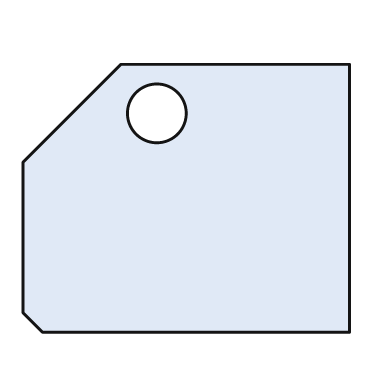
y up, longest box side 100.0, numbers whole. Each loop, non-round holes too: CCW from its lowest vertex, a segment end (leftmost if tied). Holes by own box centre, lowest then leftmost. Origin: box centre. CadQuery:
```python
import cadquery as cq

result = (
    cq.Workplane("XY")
    .moveTo(-44.0, -41.0)
    .lineTo(50.0, -41.0)
    .lineTo(50.0, 41.0)
    .lineTo(-20.0, 41.0)
    .lineTo(-50.0, 11.0)
    .lineTo(-50.0, -35.0)
    .close()
    .moveTo(-9.0, 26.0)
    .circle(9.0)
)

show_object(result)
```